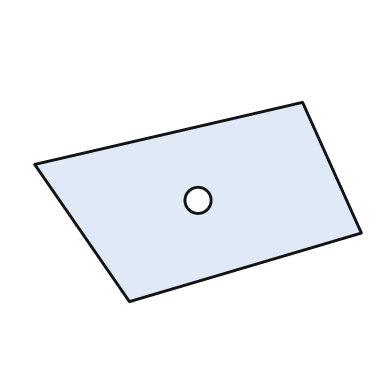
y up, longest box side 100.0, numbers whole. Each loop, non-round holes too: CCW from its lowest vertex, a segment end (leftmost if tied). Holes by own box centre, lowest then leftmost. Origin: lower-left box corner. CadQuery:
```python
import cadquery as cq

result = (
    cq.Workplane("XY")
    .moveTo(29.0, 0.0)
    .lineTo(100.0, 21.0)
    .lineTo(82.0, 61.0)
    .lineTo(0.0, 42.0)
    .close()
    .moveTo(50.0, 31.0)
    .circle(4.0)
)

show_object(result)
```